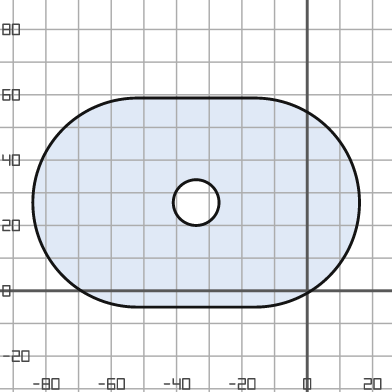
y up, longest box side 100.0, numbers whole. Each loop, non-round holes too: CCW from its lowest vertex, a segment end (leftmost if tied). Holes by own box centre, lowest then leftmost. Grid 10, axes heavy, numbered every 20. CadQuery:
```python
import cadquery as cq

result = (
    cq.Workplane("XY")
    .moveTo(-52.0, -5.0)
    .lineTo(-16.0, -5.0)
    .threePointArc((16.0, 27.0), (-16.0, 59.0))
    .lineTo(-52.0, 59.0)
    .threePointArc((-84.0, 27.0), (-52.0, -5.0))
    .close()
    .moveTo(-34.0, 27.0)
    .circle(7.0)
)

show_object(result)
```